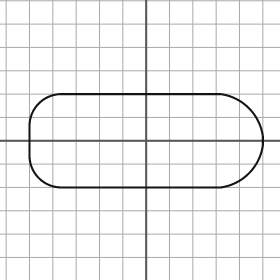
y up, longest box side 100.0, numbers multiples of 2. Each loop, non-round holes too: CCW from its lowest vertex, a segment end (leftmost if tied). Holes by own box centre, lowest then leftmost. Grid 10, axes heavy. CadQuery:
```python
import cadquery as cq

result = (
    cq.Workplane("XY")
    .moveTo(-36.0, -20.0)
    .lineTo(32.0, -20.0)
    .threePointArc((44.0, -14.0), (50.0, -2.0))
    .lineTo(50.0, 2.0)
    .threePointArc((44.0, 14.0), (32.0, 20.0))
    .lineTo(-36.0, 20.0)
    .threePointArc((-46.0, 16.0), (-50.0, 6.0))
    .lineTo(-50.0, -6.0)
    .threePointArc((-46.0, -16.0), (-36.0, -20.0))
    .close()
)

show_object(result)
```